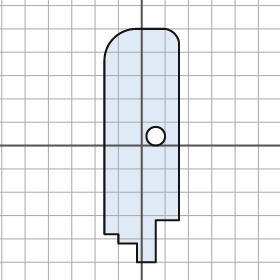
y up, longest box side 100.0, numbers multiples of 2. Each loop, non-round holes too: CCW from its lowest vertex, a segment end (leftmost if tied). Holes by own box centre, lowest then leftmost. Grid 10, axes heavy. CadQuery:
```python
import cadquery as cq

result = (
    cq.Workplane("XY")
    .moveTo(-2.0, -50.0)
    .lineTo(6.0, -50.0)
    .lineTo(6.0, -32.0)
    .lineTo(16.0, -32.0)
    .lineTo(16.0, 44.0)
    .threePointArc((14.0, 48.0), (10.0, 50.0))
    .lineTo(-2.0, 50.0)
    .threePointArc((-12.0, 46.0), (-16.0, 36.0))
    .lineTo(-16.0, -38.0)
    .lineTo(-10.0, -38.0)
    .lineTo(-10.0, -42.0)
    .lineTo(-2.0, -42.0)
    .close()
    .moveTo(6.0, 4.0)
    .circle(4.0)
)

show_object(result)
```